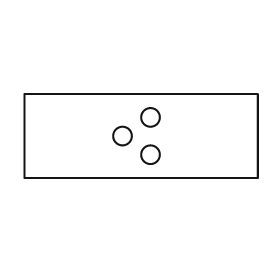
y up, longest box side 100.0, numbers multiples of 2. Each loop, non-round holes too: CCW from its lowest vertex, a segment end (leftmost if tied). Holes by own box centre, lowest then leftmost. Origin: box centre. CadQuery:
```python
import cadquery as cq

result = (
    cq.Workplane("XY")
    .moveTo(-50.0, -18.0)
    .lineTo(50.0, -18.0)
    .lineTo(50.0, 18.0)
    .lineTo(-50.0, 18.0)
    .close()
    .moveTo(4.0, -8.0)
    .circle(4.0)
    .moveTo(-8.0, 0.0)
    .circle(4.0)
    .moveTo(4.0, 8.0)
    .circle(4.0)
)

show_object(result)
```